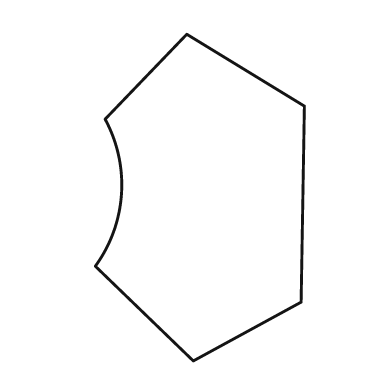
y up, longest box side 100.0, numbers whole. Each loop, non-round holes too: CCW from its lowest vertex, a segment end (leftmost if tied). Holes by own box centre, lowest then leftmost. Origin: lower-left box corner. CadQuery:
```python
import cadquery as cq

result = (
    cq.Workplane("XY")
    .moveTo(30.0, 0.0)
    .lineTo(63.0, 18.0)
    .lineTo(64.0, 78.0)
    .lineTo(28.0, 100.0)
    .lineTo(3.0, 74.0)
    .threePointArc((8.0, 51.0), (0.0, 29.0))
    .close()
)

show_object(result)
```